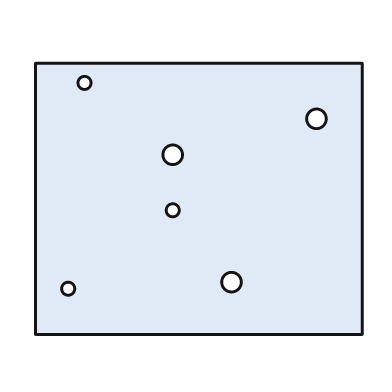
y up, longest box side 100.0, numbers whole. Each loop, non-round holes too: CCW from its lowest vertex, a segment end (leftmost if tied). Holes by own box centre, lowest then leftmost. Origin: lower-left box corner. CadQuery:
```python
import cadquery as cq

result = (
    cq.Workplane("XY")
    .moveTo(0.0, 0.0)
    .lineTo(100.0, 0.0)
    .lineTo(100.0, 83.0)
    .lineTo(0.0, 83.0)
    .close()
    .moveTo(10.0, 14.0)
    .circle(2.0)
    .moveTo(60.0, 16.0)
    .circle(3.0)
    .moveTo(42.0, 38.0)
    .circle(2.0)
    .moveTo(42.0, 55.0)
    .circle(3.0)
    .moveTo(86.0, 66.0)
    .circle(3.0)
    .moveTo(15.0, 77.0)
    .circle(2.0)
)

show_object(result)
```